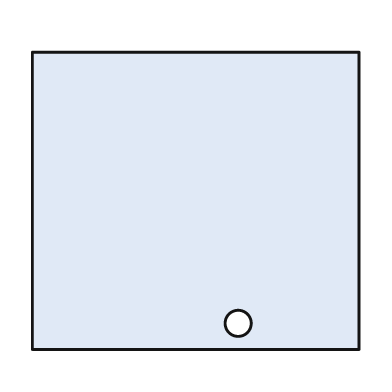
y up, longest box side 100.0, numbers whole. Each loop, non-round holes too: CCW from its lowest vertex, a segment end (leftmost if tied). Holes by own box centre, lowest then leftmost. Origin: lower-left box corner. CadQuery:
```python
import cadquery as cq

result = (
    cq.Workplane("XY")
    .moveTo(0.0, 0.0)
    .lineTo(100.0, 0.0)
    .lineTo(100.0, 91.0)
    .lineTo(0.0, 91.0)
    .close()
    .moveTo(63.0, 8.0)
    .circle(4.0)
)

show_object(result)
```